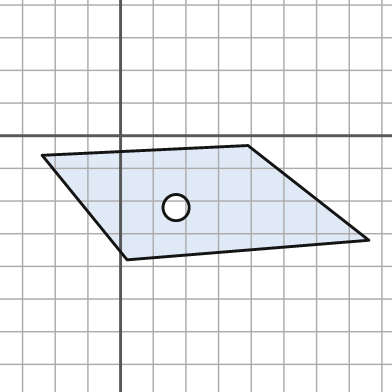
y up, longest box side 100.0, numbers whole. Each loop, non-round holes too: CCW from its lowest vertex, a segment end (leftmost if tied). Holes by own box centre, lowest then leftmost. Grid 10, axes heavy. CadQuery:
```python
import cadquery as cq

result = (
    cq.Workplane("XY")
    .moveTo(2.0, -38.0)
    .lineTo(76.0, -32.0)
    .lineTo(39.0, -3.0)
    .lineTo(-24.0, -6.0)
    .close()
    .moveTo(17.0, -22.0)
    .circle(4.0)
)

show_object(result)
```